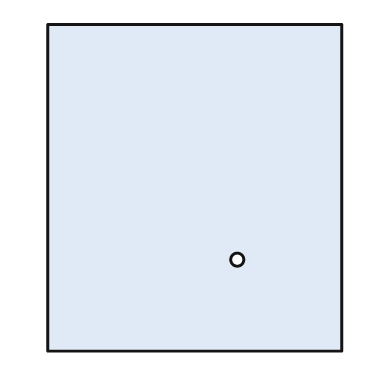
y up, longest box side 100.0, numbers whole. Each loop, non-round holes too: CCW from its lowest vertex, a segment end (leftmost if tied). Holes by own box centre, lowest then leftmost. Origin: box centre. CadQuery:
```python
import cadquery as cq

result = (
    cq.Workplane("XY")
    .moveTo(-45.0, -50.0)
    .lineTo(45.0, -50.0)
    .lineTo(45.0, 50.0)
    .lineTo(-45.0, 50.0)
    .close()
    .moveTo(13.0, -22.0)
    .circle(2.0)
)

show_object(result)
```